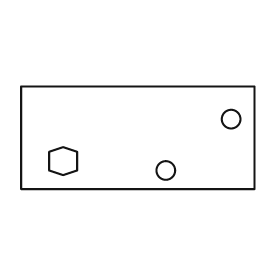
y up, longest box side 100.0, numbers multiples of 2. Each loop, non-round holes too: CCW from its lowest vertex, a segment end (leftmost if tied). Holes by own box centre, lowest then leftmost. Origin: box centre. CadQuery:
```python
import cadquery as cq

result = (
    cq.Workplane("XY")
    .moveTo(-50.0, -22.0)
    .lineTo(50.0, -22.0)
    .lineTo(50.0, 22.0)
    .lineTo(-50.0, 22.0)
    .close()
    .moveTo(12.0, -14.0)
    .circle(4.0)
    .moveTo(-32.0, -16.0)
    .lineTo(-26.0, -14.0)
    .lineTo(-26.0, -6.0)
    .lineTo(-32.0, -4.0)
    .lineTo(-38.0, -6.0)
    .lineTo(-38.0, -14.0)
    .close()
    .moveTo(40.0, 8.0)
    .circle(4.0)
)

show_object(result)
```